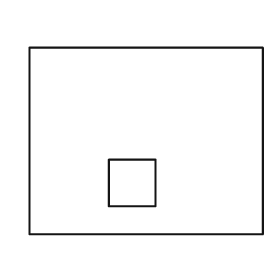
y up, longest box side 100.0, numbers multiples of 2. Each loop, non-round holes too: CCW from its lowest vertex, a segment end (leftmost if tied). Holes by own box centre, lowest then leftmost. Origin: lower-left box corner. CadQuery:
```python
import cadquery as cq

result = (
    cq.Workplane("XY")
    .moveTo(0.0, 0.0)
    .lineTo(100.0, 0.0)
    .lineTo(100.0, 80.0)
    .lineTo(0.0, 80.0)
    .close()
    .moveTo(34.0, 12.0)
    .lineTo(54.0, 12.0)
    .lineTo(54.0, 32.0)
    .lineTo(34.0, 32.0)
    .close()
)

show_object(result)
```